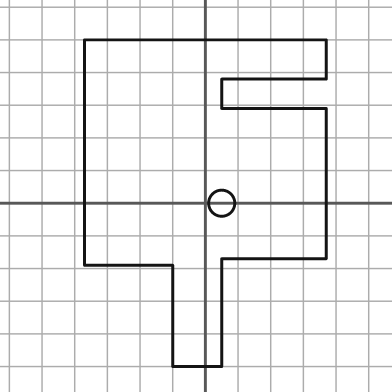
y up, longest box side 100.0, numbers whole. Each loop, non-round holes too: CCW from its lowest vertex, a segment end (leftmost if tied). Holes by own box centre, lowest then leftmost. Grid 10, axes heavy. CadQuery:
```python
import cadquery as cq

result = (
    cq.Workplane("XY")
    .moveTo(-10.0, -50.0)
    .lineTo(5.0, -50.0)
    .lineTo(5.0, -17.0)
    .lineTo(37.0, -17.0)
    .lineTo(37.0, 29.0)
    .lineTo(5.0, 29.0)
    .lineTo(5.0, 38.0)
    .lineTo(37.0, 38.0)
    .lineTo(37.0, 50.0)
    .lineTo(-37.0, 50.0)
    .lineTo(-37.0, -19.0)
    .lineTo(-10.0, -19.0)
    .close()
    .moveTo(5.0, 0.0)
    .circle(4.0)
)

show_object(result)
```